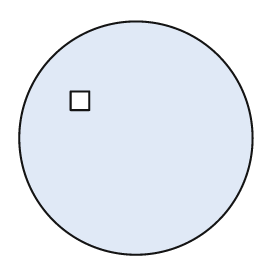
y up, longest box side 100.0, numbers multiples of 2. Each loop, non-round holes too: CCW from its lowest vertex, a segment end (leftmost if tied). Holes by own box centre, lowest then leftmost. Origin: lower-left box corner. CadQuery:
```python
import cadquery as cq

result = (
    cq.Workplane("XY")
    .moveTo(50.0, 50.0)
    .circle(50.0)
    .moveTo(22.0, 62.0)
    .lineTo(30.0, 62.0)
    .lineTo(30.0, 70.0)
    .lineTo(22.0, 70.0)
    .close()
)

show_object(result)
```